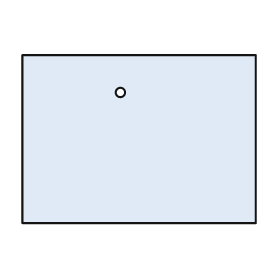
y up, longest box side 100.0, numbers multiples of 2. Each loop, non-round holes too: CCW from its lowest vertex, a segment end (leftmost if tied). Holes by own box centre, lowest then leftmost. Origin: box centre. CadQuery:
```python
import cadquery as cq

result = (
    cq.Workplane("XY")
    .moveTo(-50.0, -36.0)
    .lineTo(50.0, -36.0)
    .lineTo(50.0, 36.0)
    .lineTo(-50.0, 36.0)
    .close()
    .moveTo(-8.0, 20.0)
    .circle(2.0)
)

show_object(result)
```